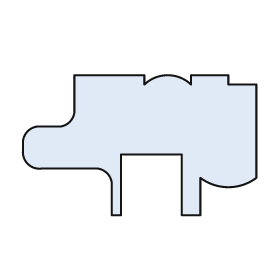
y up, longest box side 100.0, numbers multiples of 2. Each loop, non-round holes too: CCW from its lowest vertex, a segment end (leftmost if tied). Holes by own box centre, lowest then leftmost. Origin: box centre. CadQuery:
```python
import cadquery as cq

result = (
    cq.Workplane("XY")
    .moveTo(-12.0, -30.0)
    .lineTo(-8.0, -30.0)
    .lineTo(-8.0, -4.0)
    .lineTo(18.0, -4.0)
    .lineTo(18.0, -30.0)
    .lineTo(26.0, -30.0)
    .lineTo(26.0, -14.0)
    .threePointArc((38.0, -18.0), (50.0, -14.0))
    .lineTo(50.0, 26.0)
    .lineTo(38.0, 26.0)
    .lineTo(38.0, 30.0)
    .lineTo(22.0, 30.0)
    .lineTo(22.0, 26.0)
    .threePointArc((12.0, 30.0), (2.0, 26.0))
    .lineTo(2.0, 30.0)
    .lineTo(-28.0, 30.0)
    .lineTo(-28.0, 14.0)
    .threePointArc((-30.0, 10.0), (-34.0, 8.0))
    .lineTo(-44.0, 8.0)
    .threePointArc((-48.0, 6.0), (-50.0, 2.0))
    .lineTo(-50.0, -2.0)
    .threePointArc((-48.0, -8.0), (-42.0, -10.0))
    .lineTo(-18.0, -10.0)
    .threePointArc((-14.0, -12.0), (-12.0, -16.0))
    .close()
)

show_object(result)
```